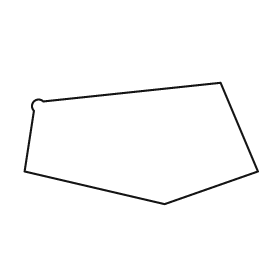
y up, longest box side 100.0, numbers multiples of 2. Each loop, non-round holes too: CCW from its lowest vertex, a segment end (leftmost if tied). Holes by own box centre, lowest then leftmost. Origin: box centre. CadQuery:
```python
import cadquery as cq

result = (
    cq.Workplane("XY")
    .moveTo(10.0, -26.0)
    .lineTo(50.0, -12.0)
    .lineTo(34.0, 26.0)
    .lineTo(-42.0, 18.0)
    .threePointArc((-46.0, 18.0), (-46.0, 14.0))
    .lineTo(-50.0, -12.0)
    .close()
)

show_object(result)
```